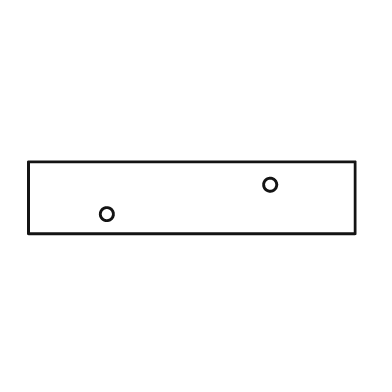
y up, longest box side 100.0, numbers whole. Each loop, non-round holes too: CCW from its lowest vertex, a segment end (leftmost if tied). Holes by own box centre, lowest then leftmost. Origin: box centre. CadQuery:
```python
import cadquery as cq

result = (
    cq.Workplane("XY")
    .moveTo(-50.0, -11.0)
    .lineTo(50.0, -11.0)
    .lineTo(50.0, 11.0)
    .lineTo(-50.0, 11.0)
    .close()
    .moveTo(-26.0, -5.0)
    .circle(2.0)
    .moveTo(24.0, 4.0)
    .circle(2.0)
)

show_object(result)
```